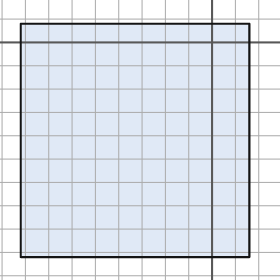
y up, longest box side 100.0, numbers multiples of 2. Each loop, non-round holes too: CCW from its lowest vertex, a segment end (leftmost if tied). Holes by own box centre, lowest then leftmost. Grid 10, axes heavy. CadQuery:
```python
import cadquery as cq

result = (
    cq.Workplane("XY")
    .moveTo(-82.0, -92.0)
    .lineTo(16.0, -92.0)
    .lineTo(16.0, 8.0)
    .lineTo(-82.0, 8.0)
    .close()
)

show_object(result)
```